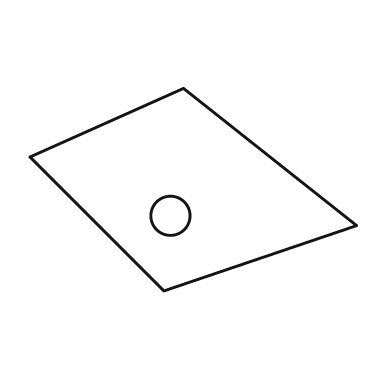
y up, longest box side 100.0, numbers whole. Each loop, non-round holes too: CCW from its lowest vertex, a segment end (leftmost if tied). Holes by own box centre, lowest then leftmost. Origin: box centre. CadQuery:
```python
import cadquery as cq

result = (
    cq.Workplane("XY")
    .moveTo(-9.0, -31.0)
    .lineTo(50.0, -11.0)
    .lineTo(-3.0, 31.0)
    .lineTo(-50.0, 10.0)
    .close()
    .moveTo(-7.0, -8.0)
    .circle(6.0)
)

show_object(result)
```